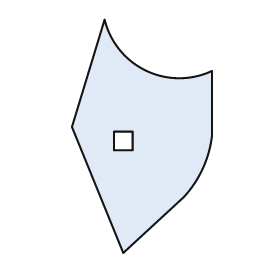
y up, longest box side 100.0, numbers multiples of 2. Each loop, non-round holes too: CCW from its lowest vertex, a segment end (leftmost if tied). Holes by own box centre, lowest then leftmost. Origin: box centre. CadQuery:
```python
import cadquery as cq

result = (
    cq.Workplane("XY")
    .moveTo(-8.0, -50.0)
    .lineTo(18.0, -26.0)
    .threePointArc((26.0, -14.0), (30.0, 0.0))
    .lineTo(30.0, 28.0)
    .threePointArc((2.0, 28.0), (-16.0, 50.0))
    .lineTo(-30.0, 4.0)
    .close()
    .moveTo(-12.0, -6.0)
    .lineTo(-4.0, -6.0)
    .lineTo(-4.0, 2.0)
    .lineTo(-12.0, 2.0)
    .close()
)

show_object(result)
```